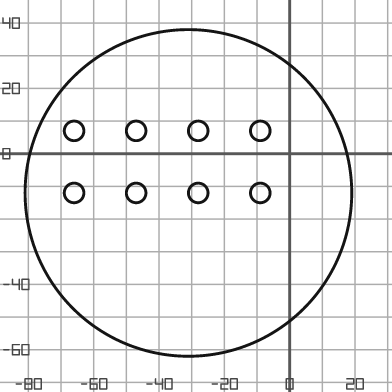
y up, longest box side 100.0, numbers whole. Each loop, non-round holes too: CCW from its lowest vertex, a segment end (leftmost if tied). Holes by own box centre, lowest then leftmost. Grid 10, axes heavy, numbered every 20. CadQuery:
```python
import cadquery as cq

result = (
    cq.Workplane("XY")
    .moveTo(-31.0, -12.0)
    .circle(50.0)
    .moveTo(-66.0, -12.0)
    .circle(3.0)
    .moveTo(-47.0, -12.0)
    .circle(3.0)
    .moveTo(-28.0, -12.0)
    .circle(3.0)
    .moveTo(-9.0, -12.0)
    .circle(3.0)
    .moveTo(-66.0, 7.0)
    .circle(3.0)
    .moveTo(-47.0, 7.0)
    .circle(3.0)
    .moveTo(-28.0, 7.0)
    .circle(3.0)
    .moveTo(-9.0, 7.0)
    .circle(3.0)
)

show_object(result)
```